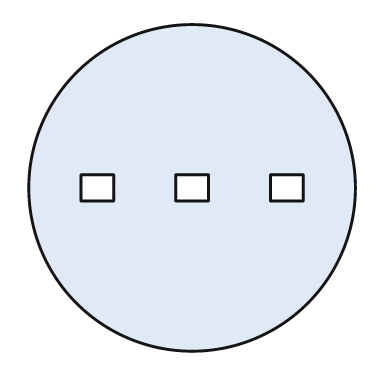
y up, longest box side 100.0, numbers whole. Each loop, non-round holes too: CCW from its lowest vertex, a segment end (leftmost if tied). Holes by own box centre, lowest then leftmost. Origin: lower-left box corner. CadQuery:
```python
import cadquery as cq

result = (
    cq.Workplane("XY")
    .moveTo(50.0, 50.0)
    .circle(50.0)
    .moveTo(16.0, 46.0)
    .lineTo(26.0, 46.0)
    .lineTo(26.0, 54.0)
    .lineTo(16.0, 54.0)
    .close()
    .moveTo(45.0, 46.0)
    .lineTo(55.0, 46.0)
    .lineTo(55.0, 54.0)
    .lineTo(45.0, 54.0)
    .close()
    .moveTo(74.0, 46.0)
    .lineTo(84.0, 46.0)
    .lineTo(84.0, 54.0)
    .lineTo(74.0, 54.0)
    .close()
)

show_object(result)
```